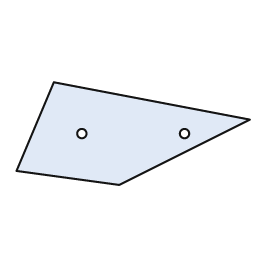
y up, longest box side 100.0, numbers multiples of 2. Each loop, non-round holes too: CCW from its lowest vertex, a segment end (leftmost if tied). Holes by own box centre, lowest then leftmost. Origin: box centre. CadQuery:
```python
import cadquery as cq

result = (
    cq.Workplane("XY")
    .moveTo(-6.0, -22.0)
    .lineTo(50.0, 6.0)
    .lineTo(-34.0, 22.0)
    .lineTo(-50.0, -16.0)
    .close()
    .moveTo(-22.0, 0.0)
    .circle(2.0)
    .moveTo(22.0, 0.0)
    .circle(2.0)
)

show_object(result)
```